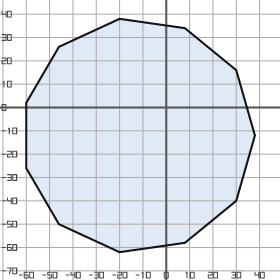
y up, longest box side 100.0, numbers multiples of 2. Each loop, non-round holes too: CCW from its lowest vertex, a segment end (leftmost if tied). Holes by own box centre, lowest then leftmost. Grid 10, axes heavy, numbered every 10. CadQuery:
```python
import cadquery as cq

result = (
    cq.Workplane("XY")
    .moveTo(-20.0, -62.0)
    .lineTo(8.0, -58.0)
    .lineTo(30.0, -40.0)
    .lineTo(38.0, -12.0)
    .lineTo(30.0, 16.0)
    .lineTo(8.0, 34.0)
    .lineTo(-20.0, 38.0)
    .lineTo(-46.0, 26.0)
    .lineTo(-60.0, 2.0)
    .lineTo(-60.0, -26.0)
    .lineTo(-46.0, -50.0)
    .close()
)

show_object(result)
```